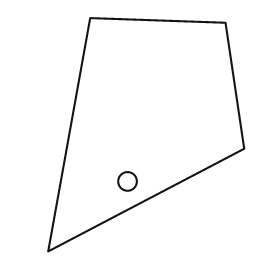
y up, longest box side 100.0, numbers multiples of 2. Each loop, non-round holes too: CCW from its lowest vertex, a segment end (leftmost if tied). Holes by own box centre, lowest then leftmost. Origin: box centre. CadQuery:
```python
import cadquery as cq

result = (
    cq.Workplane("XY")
    .moveTo(-42.0, -50.0)
    .lineTo(42.0, -6.0)
    .lineTo(34.0, 48.0)
    .lineTo(-24.0, 50.0)
    .close()
    .moveTo(-8.0, -20.0)
    .circle(4.0)
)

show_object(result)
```